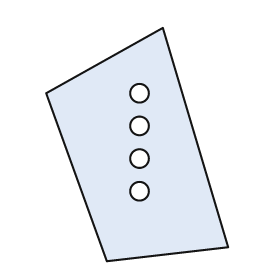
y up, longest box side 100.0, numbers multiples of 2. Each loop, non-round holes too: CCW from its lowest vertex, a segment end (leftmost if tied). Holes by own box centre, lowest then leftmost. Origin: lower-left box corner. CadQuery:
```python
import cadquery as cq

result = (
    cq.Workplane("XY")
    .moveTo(26.0, 0.0)
    .lineTo(78.0, 6.0)
    .lineTo(50.0, 100.0)
    .lineTo(0.0, 72.0)
    .close()
    .moveTo(40.0, 30.0)
    .circle(4.0)
    .moveTo(40.0, 44.0)
    .circle(4.0)
    .moveTo(40.0, 58.0)
    .circle(4.0)
    .moveTo(40.0, 72.0)
    .circle(4.0)
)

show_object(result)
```